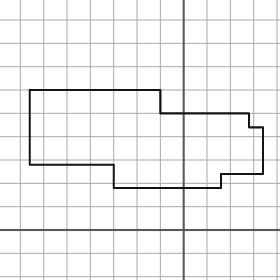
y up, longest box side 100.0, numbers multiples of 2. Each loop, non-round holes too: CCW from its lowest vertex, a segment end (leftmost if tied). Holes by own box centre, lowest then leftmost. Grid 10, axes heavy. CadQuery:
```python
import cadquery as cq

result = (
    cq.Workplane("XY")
    .moveTo(-30.0, 18.0)
    .lineTo(16.0, 18.0)
    .lineTo(16.0, 24.0)
    .lineTo(34.0, 24.0)
    .lineTo(34.0, 44.0)
    .lineTo(28.0, 44.0)
    .lineTo(28.0, 50.0)
    .lineTo(-10.0, 50.0)
    .lineTo(-10.0, 60.0)
    .lineTo(-66.0, 60.0)
    .lineTo(-66.0, 28.0)
    .lineTo(-30.0, 28.0)
    .close()
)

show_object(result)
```